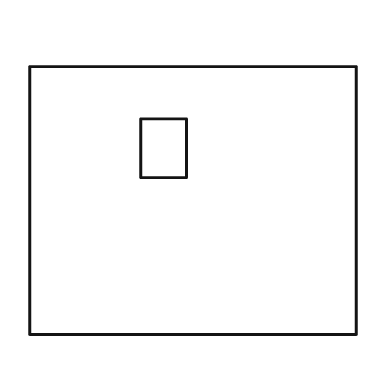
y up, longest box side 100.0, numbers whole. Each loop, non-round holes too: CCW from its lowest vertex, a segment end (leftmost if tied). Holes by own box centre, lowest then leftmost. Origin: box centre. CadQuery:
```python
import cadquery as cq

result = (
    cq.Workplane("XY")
    .moveTo(-50.0, -41.0)
    .lineTo(50.0, -41.0)
    .lineTo(50.0, 41.0)
    .lineTo(-50.0, 41.0)
    .close()
    .moveTo(-16.0, 7.0)
    .lineTo(-2.0, 7.0)
    .lineTo(-2.0, 25.0)
    .lineTo(-16.0, 25.0)
    .close()
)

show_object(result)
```